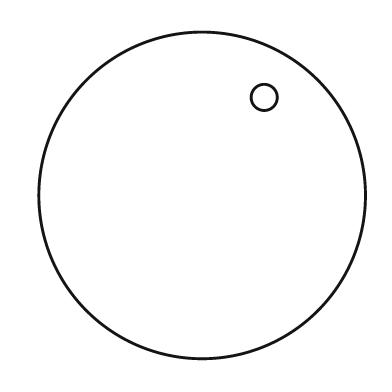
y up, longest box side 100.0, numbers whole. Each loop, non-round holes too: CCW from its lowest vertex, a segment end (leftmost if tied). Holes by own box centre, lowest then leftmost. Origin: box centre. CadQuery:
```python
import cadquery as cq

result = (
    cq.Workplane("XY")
    .moveTo(0.0, 0.0)
    .circle(50.0)
    .moveTo(19.0, 30.0)
    .circle(4.0)
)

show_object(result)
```